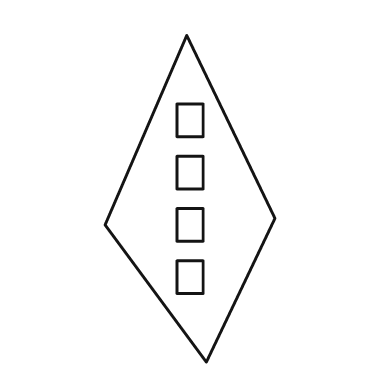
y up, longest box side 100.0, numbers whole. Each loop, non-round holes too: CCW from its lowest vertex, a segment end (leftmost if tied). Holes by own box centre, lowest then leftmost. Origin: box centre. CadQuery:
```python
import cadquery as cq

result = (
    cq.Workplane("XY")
    .moveTo(5.0, -50.0)
    .lineTo(26.0, -6.0)
    .lineTo(-1.0, 50.0)
    .lineTo(-26.0, -8.0)
    .close()
    .moveTo(-4.0, -29.0)
    .lineTo(4.0, -29.0)
    .lineTo(4.0, -19.0)
    .lineTo(-4.0, -19.0)
    .close()
    .moveTo(-4.0, -13.0)
    .lineTo(4.0, -13.0)
    .lineTo(4.0, -3.0)
    .lineTo(-4.0, -3.0)
    .close()
    .moveTo(-4.0, 3.0)
    .lineTo(4.0, 3.0)
    .lineTo(4.0, 13.0)
    .lineTo(-4.0, 13.0)
    .close()
    .moveTo(-4.0, 19.0)
    .lineTo(4.0, 19.0)
    .lineTo(4.0, 29.0)
    .lineTo(-4.0, 29.0)
    .close()
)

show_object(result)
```